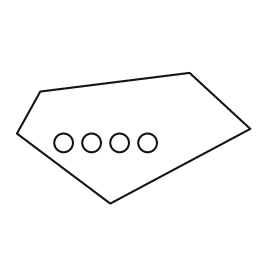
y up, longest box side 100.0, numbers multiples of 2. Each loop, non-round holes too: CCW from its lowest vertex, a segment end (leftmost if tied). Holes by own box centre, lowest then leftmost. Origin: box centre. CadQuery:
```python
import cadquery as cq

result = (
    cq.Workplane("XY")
    .moveTo(-10.0, -28.0)
    .lineTo(50.0, 4.0)
    .lineTo(24.0, 28.0)
    .lineTo(-40.0, 20.0)
    .lineTo(-50.0, 2.0)
    .close()
    .moveTo(-30.0, -2.0)
    .circle(4.0)
    .moveTo(-18.0, -2.0)
    .circle(4.0)
    .moveTo(-6.0, -2.0)
    .circle(4.0)
    .moveTo(6.0, -2.0)
    .circle(4.0)
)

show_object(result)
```